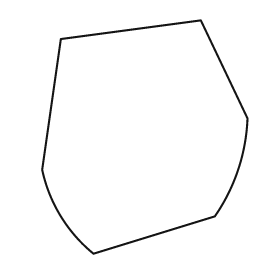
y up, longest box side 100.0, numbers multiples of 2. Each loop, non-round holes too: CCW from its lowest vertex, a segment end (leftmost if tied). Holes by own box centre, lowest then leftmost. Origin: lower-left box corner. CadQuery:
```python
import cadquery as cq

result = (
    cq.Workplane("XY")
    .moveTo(22.0, 0.0)
    .lineTo(74.0, 16.0)
    .threePointArc((84.0, 36.0), (88.0, 58.0))
    .lineTo(68.0, 100.0)
    .lineTo(8.0, 92.0)
    .lineTo(0.0, 36.0)
    .threePointArc((8.0, 16.0), (22.0, 0.0))
    .close()
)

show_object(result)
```